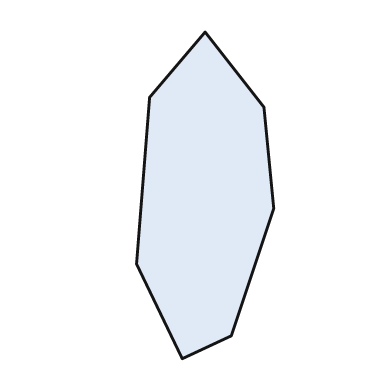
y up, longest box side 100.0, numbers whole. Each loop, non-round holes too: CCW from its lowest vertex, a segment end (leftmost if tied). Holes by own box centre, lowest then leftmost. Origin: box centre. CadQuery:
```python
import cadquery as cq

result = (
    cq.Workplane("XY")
    .moveTo(-7.0, -50.0)
    .lineTo(8.0, -43.0)
    .lineTo(21.0, -4.0)
    .lineTo(18.0, 27.0)
    .lineTo(0.0, 50.0)
    .lineTo(-17.0, 30.0)
    .lineTo(-21.0, -21.0)
    .close()
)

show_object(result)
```